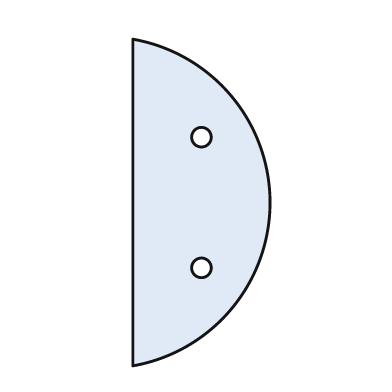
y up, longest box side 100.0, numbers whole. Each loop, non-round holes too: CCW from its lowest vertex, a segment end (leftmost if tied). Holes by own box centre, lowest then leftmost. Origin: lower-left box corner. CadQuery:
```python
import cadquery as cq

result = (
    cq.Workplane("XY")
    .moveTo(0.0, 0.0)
    .threePointArc((42.0, 50.0), (0.0, 100.0))
    .close()
    .moveTo(21.0, 30.0)
    .circle(3.0)
    .moveTo(21.0, 70.0)
    .circle(3.0)
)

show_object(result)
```